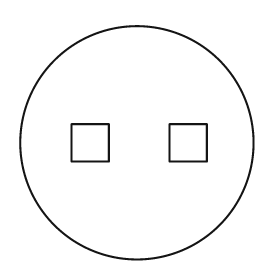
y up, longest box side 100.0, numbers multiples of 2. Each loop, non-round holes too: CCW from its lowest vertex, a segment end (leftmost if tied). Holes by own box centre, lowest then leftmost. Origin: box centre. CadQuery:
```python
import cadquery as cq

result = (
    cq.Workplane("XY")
    .moveTo(0.0, 0.0)
    .circle(50.0)
    .moveTo(-28.0, -8.0)
    .lineTo(-12.0, -8.0)
    .lineTo(-12.0, 8.0)
    .lineTo(-28.0, 8.0)
    .close()
    .moveTo(14.0, -8.0)
    .lineTo(30.0, -8.0)
    .lineTo(30.0, 8.0)
    .lineTo(14.0, 8.0)
    .close()
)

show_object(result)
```